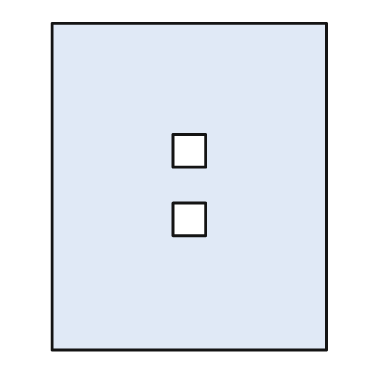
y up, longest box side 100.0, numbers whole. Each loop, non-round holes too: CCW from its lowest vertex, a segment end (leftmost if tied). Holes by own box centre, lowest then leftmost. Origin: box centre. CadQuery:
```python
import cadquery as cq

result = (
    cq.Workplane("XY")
    .moveTo(-42.0, -50.0)
    .lineTo(42.0, -50.0)
    .lineTo(42.0, 50.0)
    .lineTo(-42.0, 50.0)
    .close()
    .moveTo(-5.0, -15.0)
    .lineTo(5.0, -15.0)
    .lineTo(5.0, -5.0)
    .lineTo(-5.0, -5.0)
    .close()
    .moveTo(-5.0, 6.0)
    .lineTo(5.0, 6.0)
    .lineTo(5.0, 16.0)
    .lineTo(-5.0, 16.0)
    .close()
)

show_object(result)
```